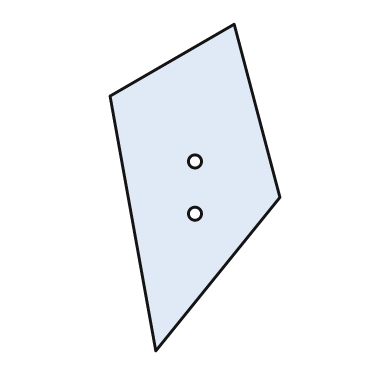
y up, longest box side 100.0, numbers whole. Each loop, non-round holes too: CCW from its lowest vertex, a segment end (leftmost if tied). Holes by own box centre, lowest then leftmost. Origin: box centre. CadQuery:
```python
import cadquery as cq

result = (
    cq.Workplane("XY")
    .moveTo(-12.0, -50.0)
    .lineTo(26.0, -3.0)
    .lineTo(12.0, 50.0)
    .lineTo(-26.0, 28.0)
    .close()
    .moveTo(0.0, -8.0)
    .circle(2.0)
    .moveTo(0.0, 8.0)
    .circle(2.0)
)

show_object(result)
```